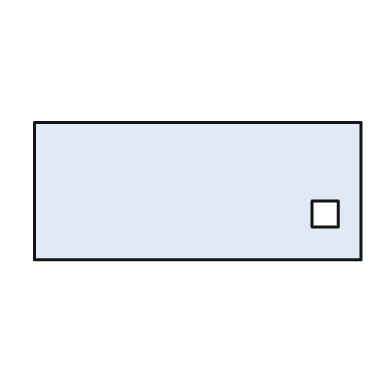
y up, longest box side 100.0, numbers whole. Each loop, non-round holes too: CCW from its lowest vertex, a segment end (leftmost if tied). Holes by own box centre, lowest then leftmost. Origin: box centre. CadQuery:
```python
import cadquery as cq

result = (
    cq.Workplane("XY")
    .moveTo(-50.0, -21.0)
    .lineTo(50.0, -21.0)
    .lineTo(50.0, 21.0)
    .lineTo(-50.0, 21.0)
    .close()
    .moveTo(35.0, -11.0)
    .lineTo(43.0, -11.0)
    .lineTo(43.0, -3.0)
    .lineTo(35.0, -3.0)
    .close()
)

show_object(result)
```